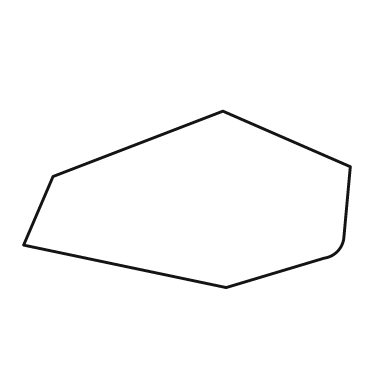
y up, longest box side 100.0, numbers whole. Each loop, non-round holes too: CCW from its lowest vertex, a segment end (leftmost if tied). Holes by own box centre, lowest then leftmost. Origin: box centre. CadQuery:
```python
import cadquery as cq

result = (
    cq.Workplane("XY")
    .moveTo(12.0, -27.0)
    .lineTo(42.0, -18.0)
    .threePointArc((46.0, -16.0), (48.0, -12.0))
    .lineTo(50.0, 10.0)
    .lineTo(11.0, 27.0)
    .lineTo(-41.0, 7.0)
    .lineTo(-50.0, -14.0)
    .close()
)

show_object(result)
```